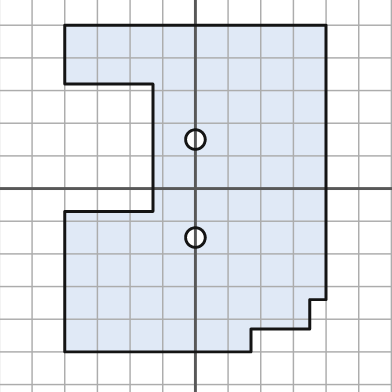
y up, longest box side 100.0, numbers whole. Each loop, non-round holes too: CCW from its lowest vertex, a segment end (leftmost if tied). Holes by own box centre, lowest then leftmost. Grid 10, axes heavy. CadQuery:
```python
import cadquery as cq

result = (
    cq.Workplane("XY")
    .moveTo(-40.0, -50.0)
    .lineTo(17.0, -50.0)
    .lineTo(17.0, -43.0)
    .lineTo(35.0, -43.0)
    .lineTo(35.0, -34.0)
    .lineTo(40.0, -34.0)
    .lineTo(40.0, 50.0)
    .lineTo(-40.0, 50.0)
    .lineTo(-40.0, 32.0)
    .lineTo(-13.0, 32.0)
    .lineTo(-13.0, -7.0)
    .lineTo(-40.0, -7.0)
    .close()
    .moveTo(0.0, -15.0)
    .circle(3.0)
    .moveTo(0.0, 15.0)
    .circle(3.0)
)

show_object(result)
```